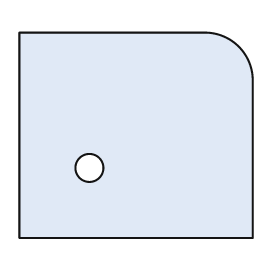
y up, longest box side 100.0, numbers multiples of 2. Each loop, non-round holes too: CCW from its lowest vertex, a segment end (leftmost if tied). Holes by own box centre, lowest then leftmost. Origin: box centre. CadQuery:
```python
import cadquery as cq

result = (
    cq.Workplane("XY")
    .moveTo(-50.0, -44.0)
    .lineTo(50.0, -44.0)
    .lineTo(50.0, 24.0)
    .threePointArc((44.0, 38.0), (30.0, 44.0))
    .lineTo(-50.0, 44.0)
    .close()
    .moveTo(-20.0, -14.0)
    .circle(6.0)
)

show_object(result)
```